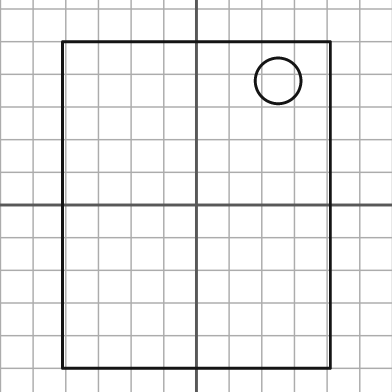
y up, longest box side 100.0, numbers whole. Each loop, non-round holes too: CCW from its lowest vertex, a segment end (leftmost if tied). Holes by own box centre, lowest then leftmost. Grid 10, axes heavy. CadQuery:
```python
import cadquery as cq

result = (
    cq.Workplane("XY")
    .moveTo(-41.0, -50.0)
    .lineTo(41.0, -50.0)
    .lineTo(41.0, 50.0)
    .lineTo(-41.0, 50.0)
    .close()
    .moveTo(25.0, 38.0)
    .circle(7.0)
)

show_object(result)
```